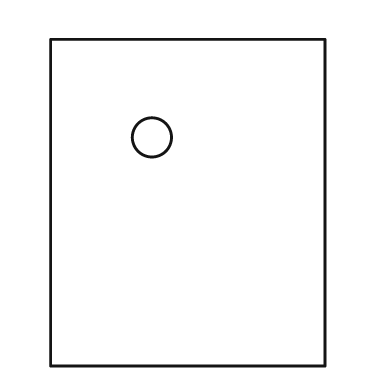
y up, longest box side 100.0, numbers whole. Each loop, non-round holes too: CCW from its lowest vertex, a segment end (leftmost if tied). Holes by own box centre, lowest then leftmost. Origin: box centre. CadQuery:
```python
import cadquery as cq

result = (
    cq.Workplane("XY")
    .moveTo(-42.0, -50.0)
    .lineTo(42.0, -50.0)
    .lineTo(42.0, 50.0)
    .lineTo(-42.0, 50.0)
    .close()
    .moveTo(-11.0, 20.0)
    .circle(6.0)
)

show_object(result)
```